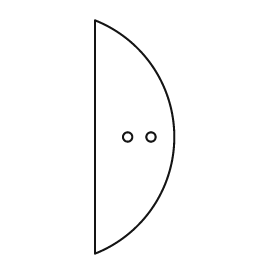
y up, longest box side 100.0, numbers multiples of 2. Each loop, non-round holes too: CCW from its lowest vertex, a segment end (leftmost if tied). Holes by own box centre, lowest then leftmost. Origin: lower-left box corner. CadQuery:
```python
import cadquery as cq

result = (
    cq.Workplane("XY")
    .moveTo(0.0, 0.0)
    .threePointArc((34.0, 50.0), (0.0, 100.0))
    .close()
    .moveTo(14.0, 50.0)
    .circle(2.0)
    .moveTo(24.0, 50.0)
    .circle(2.0)
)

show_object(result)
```